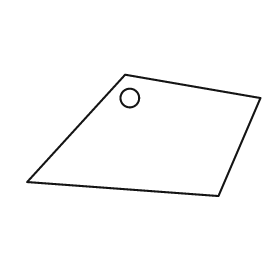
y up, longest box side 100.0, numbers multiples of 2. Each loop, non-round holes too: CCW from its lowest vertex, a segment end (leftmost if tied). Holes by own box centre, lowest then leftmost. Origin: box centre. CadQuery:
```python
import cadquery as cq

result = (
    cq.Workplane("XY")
    .moveTo(32.0, -26.0)
    .lineTo(50.0, 16.0)
    .lineTo(-8.0, 26.0)
    .lineTo(-50.0, -20.0)
    .close()
    .moveTo(-6.0, 16.0)
    .circle(4.0)
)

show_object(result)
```